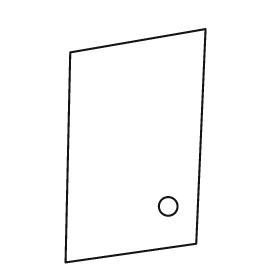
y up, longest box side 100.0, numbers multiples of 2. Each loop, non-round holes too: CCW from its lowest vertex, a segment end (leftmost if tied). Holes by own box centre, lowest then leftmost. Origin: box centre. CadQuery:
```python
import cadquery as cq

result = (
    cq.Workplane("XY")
    .moveTo(-30.0, -50.0)
    .lineTo(26.0, -42.0)
    .lineTo(30.0, 50.0)
    .lineTo(-28.0, 40.0)
    .close()
    .moveTo(14.0, -26.0)
    .circle(4.0)
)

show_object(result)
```